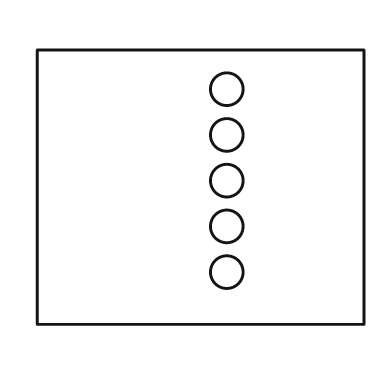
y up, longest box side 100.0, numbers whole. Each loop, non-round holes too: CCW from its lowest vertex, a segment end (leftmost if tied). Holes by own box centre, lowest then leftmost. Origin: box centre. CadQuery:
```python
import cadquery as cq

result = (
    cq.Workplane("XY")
    .moveTo(-50.0, -42.0)
    .lineTo(50.0, -42.0)
    .lineTo(50.0, 42.0)
    .lineTo(-50.0, 42.0)
    .close()
    .moveTo(8.0, -26.0)
    .circle(5.0)
    .moveTo(8.0, -12.0)
    .circle(5.0)
    .moveTo(8.0, 2.0)
    .circle(5.0)
    .moveTo(8.0, 16.0)
    .circle(5.0)
    .moveTo(8.0, 30.0)
    .circle(5.0)
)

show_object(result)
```